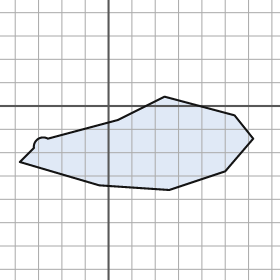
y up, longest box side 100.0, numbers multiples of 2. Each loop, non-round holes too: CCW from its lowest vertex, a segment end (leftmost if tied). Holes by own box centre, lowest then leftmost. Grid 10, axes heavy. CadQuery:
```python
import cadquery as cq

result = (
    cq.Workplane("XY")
    .moveTo(26.0, -36.0)
    .lineTo(50.0, -28.0)
    .lineTo(62.0, -14.0)
    .lineTo(54.0, -4.0)
    .lineTo(24.0, 4.0)
    .lineTo(4.0, -6.0)
    .lineTo(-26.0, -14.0)
    .threePointArc((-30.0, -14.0), (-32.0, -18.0))
    .lineTo(-38.0, -24.0)
    .lineTo(-4.0, -34.0)
    .close()
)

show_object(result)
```